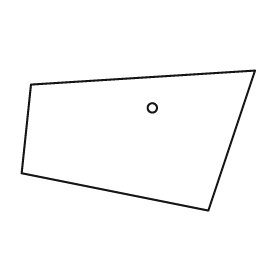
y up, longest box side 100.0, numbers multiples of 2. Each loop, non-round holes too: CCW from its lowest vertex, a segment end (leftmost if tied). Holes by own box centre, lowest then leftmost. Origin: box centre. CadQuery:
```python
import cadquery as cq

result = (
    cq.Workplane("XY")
    .moveTo(30.0, -30.0)
    .lineTo(50.0, 30.0)
    .lineTo(-46.0, 24.0)
    .lineTo(-50.0, -14.0)
    .close()
    .moveTo(6.0, 14.0)
    .circle(2.0)
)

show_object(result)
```